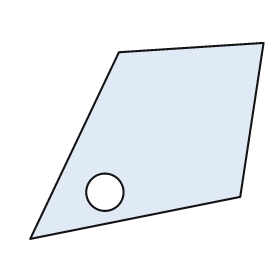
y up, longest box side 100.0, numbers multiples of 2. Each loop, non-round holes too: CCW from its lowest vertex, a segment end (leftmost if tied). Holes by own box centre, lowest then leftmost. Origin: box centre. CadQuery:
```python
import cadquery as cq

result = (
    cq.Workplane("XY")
    .moveTo(-50.0, -42.0)
    .lineTo(40.0, -24.0)
    .lineTo(50.0, 42.0)
    .lineTo(-12.0, 38.0)
    .close()
    .moveTo(-18.0, -22.0)
    .circle(8.0)
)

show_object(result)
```